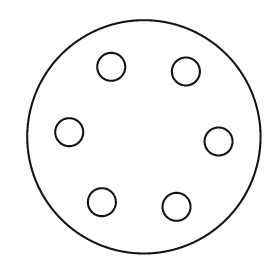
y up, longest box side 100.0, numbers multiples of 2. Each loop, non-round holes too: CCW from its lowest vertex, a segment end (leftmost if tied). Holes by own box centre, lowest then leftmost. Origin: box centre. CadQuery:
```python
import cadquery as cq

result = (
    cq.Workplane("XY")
    .moveTo(0.0, 0.0)
    .circle(50.0)
    .moveTo(14.0, -30.0)
    .circle(6.0)
    .moveTo(-18.0, -28.0)
    .circle(6.0)
    .moveTo(32.0, -2.0)
    .circle(6.0)
    .moveTo(-32.0, 2.0)
    .circle(6.0)
    .moveTo(18.0, 28.0)
    .circle(6.0)
    .moveTo(-14.0, 30.0)
    .circle(6.0)
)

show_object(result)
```